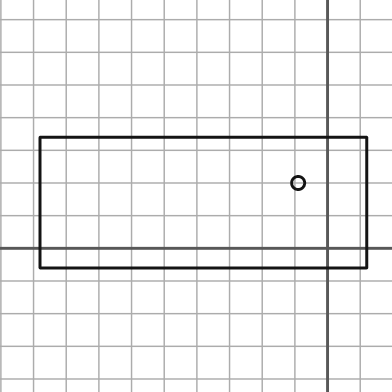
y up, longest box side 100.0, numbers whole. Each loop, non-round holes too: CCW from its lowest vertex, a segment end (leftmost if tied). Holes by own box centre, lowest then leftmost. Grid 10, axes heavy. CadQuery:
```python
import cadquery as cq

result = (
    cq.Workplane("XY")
    .moveTo(-88.0, -6.0)
    .lineTo(12.0, -6.0)
    .lineTo(12.0, 34.0)
    .lineTo(-88.0, 34.0)
    .close()
    .moveTo(-9.0, 20.0)
    .circle(2.0)
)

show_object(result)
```